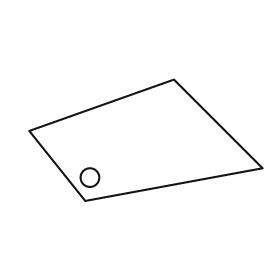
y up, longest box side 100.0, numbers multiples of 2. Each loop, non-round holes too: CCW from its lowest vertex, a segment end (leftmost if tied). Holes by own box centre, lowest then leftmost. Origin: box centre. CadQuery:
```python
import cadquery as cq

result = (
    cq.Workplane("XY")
    .moveTo(-26.0, -26.0)
    .lineTo(50.0, -12.0)
    .lineTo(12.0, 26.0)
    .lineTo(-50.0, 4.0)
    .close()
    .moveTo(-24.0, -16.0)
    .circle(4.0)
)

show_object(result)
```